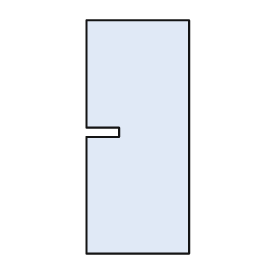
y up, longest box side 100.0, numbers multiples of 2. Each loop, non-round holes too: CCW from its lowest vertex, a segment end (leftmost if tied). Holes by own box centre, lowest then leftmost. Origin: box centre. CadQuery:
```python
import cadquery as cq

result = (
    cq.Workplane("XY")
    .moveTo(-22.0, -50.0)
    .lineTo(22.0, -50.0)
    .lineTo(22.0, 50.0)
    .lineTo(-22.0, 50.0)
    .lineTo(-22.0, 4.0)
    .lineTo(-8.0, 4.0)
    .lineTo(-8.0, 0.0)
    .lineTo(-22.0, 0.0)
    .close()
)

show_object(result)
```